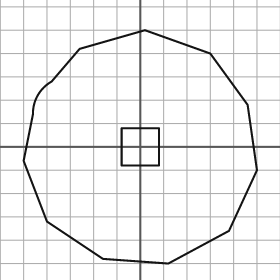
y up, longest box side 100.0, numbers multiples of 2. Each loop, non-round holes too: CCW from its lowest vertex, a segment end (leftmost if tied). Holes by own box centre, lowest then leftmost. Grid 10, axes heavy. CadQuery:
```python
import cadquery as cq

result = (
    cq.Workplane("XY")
    .moveTo(12.0, -50.0)
    .lineTo(38.0, -36.0)
    .lineTo(50.0, -10.0)
    .lineTo(46.0, 18.0)
    .lineTo(30.0, 40.0)
    .lineTo(2.0, 50.0)
    .lineTo(-26.0, 42.0)
    .lineTo(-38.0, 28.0)
    .threePointArc((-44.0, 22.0), (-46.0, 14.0))
    .lineTo(-50.0, -6.0)
    .lineTo(-40.0, -32.0)
    .lineTo(-16.0, -48.0)
    .close()
    .moveTo(-8.0, -8.0)
    .lineTo(8.0, -8.0)
    .lineTo(8.0, 8.0)
    .lineTo(-8.0, 8.0)
    .close()
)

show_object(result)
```